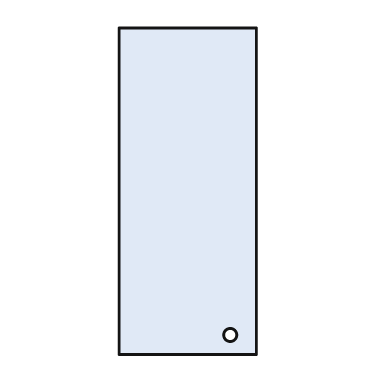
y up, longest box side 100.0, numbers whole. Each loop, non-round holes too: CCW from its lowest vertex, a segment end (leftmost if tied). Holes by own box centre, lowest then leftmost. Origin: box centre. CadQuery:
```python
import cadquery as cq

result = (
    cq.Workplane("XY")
    .moveTo(-21.0, -50.0)
    .lineTo(21.0, -50.0)
    .lineTo(21.0, 50.0)
    .lineTo(-21.0, 50.0)
    .close()
    .moveTo(13.0, -44.0)
    .circle(2.0)
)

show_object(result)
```